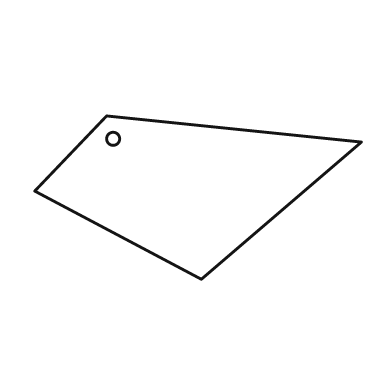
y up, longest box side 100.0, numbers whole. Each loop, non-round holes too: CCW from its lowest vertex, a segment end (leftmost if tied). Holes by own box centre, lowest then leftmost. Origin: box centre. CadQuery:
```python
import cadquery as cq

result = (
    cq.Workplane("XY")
    .moveTo(1.0, -25.0)
    .lineTo(50.0, 17.0)
    .lineTo(-28.0, 25.0)
    .lineTo(-50.0, 2.0)
    .close()
    .moveTo(-26.0, 18.0)
    .circle(2.0)
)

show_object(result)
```